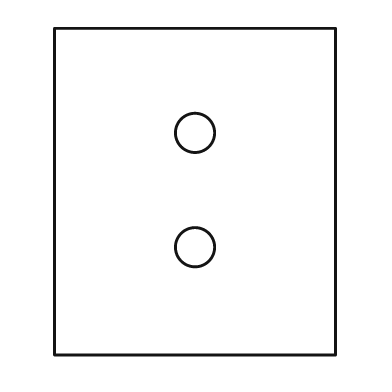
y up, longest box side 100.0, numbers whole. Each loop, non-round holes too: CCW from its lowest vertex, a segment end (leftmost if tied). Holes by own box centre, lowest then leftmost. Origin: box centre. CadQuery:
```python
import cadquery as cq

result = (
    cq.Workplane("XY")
    .moveTo(-43.0, -50.0)
    .lineTo(43.0, -50.0)
    .lineTo(43.0, 50.0)
    .lineTo(-43.0, 50.0)
    .close()
    .moveTo(0.0, -17.0)
    .circle(6.0)
    .moveTo(0.0, 18.0)
    .circle(6.0)
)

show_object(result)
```